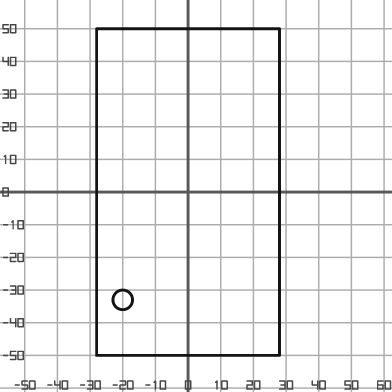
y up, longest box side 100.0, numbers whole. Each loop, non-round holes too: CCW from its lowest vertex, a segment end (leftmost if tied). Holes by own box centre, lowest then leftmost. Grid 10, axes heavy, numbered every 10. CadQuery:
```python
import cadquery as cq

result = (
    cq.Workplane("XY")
    .moveTo(-28.0, -50.0)
    .lineTo(28.0, -50.0)
    .lineTo(28.0, 50.0)
    .lineTo(-28.0, 50.0)
    .close()
    .moveTo(-20.0, -33.0)
    .circle(3.0)
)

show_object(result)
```